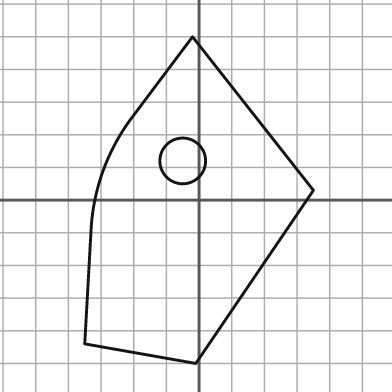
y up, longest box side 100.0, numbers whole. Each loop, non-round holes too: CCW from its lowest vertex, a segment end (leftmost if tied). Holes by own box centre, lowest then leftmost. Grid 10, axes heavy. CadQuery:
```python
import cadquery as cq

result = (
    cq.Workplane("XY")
    .moveTo(-1.0, -50.0)
    .lineTo(35.0, 3.0)
    .lineTo(-2.0, 50.0)
    .lineTo(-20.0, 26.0)
    .threePointArc((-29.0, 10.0), (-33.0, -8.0))
    .lineTo(-35.0, -44.0)
    .close()
    .moveTo(-5.0, 12.0)
    .circle(7.0)
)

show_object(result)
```